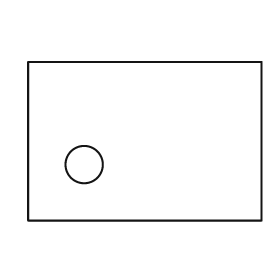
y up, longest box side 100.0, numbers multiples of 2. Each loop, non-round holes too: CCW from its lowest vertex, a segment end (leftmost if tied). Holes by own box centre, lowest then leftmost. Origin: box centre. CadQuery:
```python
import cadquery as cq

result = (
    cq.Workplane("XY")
    .moveTo(-50.0, -34.0)
    .lineTo(50.0, -34.0)
    .lineTo(50.0, 34.0)
    .lineTo(-50.0, 34.0)
    .close()
    .moveTo(-26.0, -10.0)
    .circle(8.0)
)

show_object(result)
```